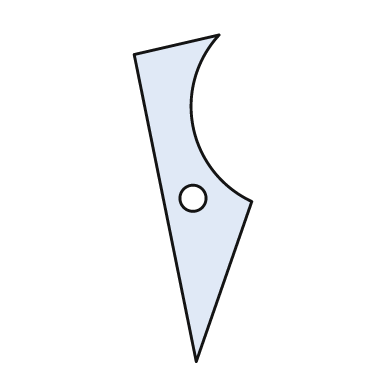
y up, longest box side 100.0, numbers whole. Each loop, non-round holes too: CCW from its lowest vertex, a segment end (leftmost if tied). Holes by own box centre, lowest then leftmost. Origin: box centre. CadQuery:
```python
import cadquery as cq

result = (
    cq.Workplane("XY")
    .moveTo(1.0, -50.0)
    .lineTo(18.0, -1.0)
    .threePointArc((0.0, 22.0), (8.0, 50.0))
    .lineTo(-18.0, 44.0)
    .close()
    .moveTo(0.0, 0.0)
    .circle(4.0)
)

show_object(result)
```